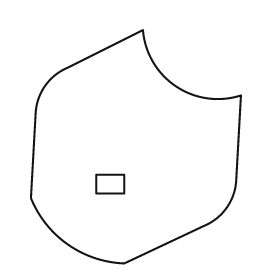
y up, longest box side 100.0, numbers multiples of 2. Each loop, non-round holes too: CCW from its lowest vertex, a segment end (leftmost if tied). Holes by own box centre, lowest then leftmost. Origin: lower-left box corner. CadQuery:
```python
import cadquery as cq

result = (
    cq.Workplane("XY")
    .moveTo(40.0, 0.0)
    .lineTo(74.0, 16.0)
    .threePointArc((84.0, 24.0), (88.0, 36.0))
    .lineTo(90.0, 72.0)
    .threePointArc((62.0, 76.0), (48.0, 100.0))
    .lineTo(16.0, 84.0)
    .threePointArc((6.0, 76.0), (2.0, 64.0))
    .lineTo(0.0, 28.0)
    .threePointArc((16.0, 8.0), (40.0, 0.0))
    .close()
    .moveTo(28.0, 30.0)
    .lineTo(40.0, 30.0)
    .lineTo(40.0, 38.0)
    .lineTo(28.0, 38.0)
    .close()
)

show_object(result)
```